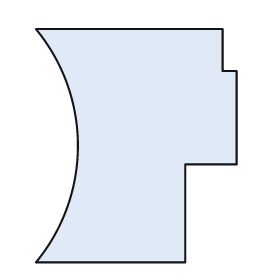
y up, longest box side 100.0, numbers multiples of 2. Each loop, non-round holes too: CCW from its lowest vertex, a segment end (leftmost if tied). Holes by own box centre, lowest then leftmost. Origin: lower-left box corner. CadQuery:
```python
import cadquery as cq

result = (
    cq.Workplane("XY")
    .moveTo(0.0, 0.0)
    .lineTo(64.0, 0.0)
    .lineTo(64.0, 42.0)
    .lineTo(86.0, 42.0)
    .lineTo(86.0, 82.0)
    .lineTo(80.0, 82.0)
    .lineTo(80.0, 100.0)
    .lineTo(0.0, 100.0)
    .threePointArc((18.0, 50.0), (0.0, 0.0))
    .close()
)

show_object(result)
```